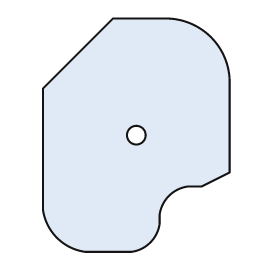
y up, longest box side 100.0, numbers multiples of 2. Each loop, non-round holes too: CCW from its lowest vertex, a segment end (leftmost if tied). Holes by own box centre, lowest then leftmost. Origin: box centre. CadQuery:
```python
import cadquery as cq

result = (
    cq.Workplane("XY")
    .moveTo(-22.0, -50.0)
    .lineTo(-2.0, -50.0)
    .threePointArc((6.0, -46.0), (10.0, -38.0))
    .lineTo(10.0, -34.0)
    .threePointArc((14.0, -26.0), (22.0, -22.0))
    .lineTo(28.0, -22.0)
    .lineTo(40.0, -16.0)
    .lineTo(40.0, 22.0)
    .threePointArc((32.0, 42.0), (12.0, 50.0))
    .lineTo(-10.0, 50.0)
    .lineTo(-40.0, 20.0)
    .lineTo(-40.0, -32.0)
    .threePointArc((-34.0, -44.0), (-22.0, -50.0))
    .close()
    .moveTo(0.0, 0.0)
    .circle(4.0)
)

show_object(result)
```